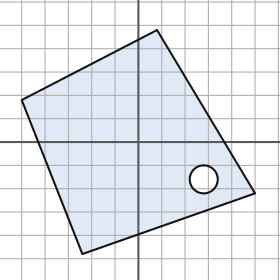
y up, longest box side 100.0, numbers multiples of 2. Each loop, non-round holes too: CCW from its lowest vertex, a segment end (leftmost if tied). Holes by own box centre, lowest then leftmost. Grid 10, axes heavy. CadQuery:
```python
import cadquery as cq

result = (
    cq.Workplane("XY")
    .moveTo(-24.0, -48.0)
    .lineTo(50.0, -22.0)
    .lineTo(8.0, 48.0)
    .lineTo(-50.0, 18.0)
    .close()
    .moveTo(28.0, -16.0)
    .circle(6.0)
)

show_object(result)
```